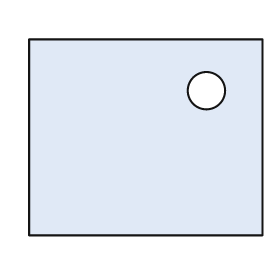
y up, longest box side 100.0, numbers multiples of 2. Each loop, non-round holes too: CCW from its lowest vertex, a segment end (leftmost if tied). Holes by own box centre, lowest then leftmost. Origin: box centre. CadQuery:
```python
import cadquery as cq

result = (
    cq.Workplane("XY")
    .moveTo(-50.0, -42.0)
    .lineTo(50.0, -42.0)
    .lineTo(50.0, 42.0)
    .lineTo(-50.0, 42.0)
    .close()
    .moveTo(26.0, 20.0)
    .circle(8.0)
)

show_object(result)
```